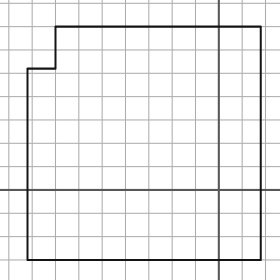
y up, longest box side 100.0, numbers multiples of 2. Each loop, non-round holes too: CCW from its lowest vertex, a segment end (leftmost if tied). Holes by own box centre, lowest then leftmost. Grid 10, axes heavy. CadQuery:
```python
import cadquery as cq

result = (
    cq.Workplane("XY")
    .moveTo(-82.0, -30.0)
    .lineTo(18.0, -30.0)
    .lineTo(18.0, 70.0)
    .lineTo(-70.0, 70.0)
    .lineTo(-70.0, 52.0)
    .lineTo(-82.0, 52.0)
    .close()
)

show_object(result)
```